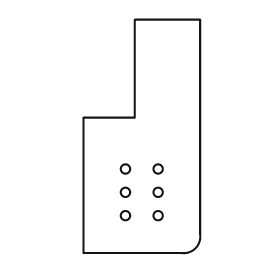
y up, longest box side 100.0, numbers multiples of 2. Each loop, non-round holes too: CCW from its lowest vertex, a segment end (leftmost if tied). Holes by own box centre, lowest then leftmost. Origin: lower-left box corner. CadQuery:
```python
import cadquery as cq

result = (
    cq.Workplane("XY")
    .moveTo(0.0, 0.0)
    .lineTo(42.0, 0.0)
    .threePointArc((48.0, 2.0), (50.0, 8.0))
    .lineTo(50.0, 100.0)
    .lineTo(22.0, 100.0)
    .lineTo(22.0, 58.0)
    .lineTo(0.0, 58.0)
    .close()
    .moveTo(18.0, 16.0)
    .circle(2.0)
    .moveTo(32.0, 16.0)
    .circle(2.0)
    .moveTo(18.0, 26.0)
    .circle(2.0)
    .moveTo(32.0, 26.0)
    .circle(2.0)
    .moveTo(18.0, 36.0)
    .circle(2.0)
    .moveTo(32.0, 36.0)
    .circle(2.0)
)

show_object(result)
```